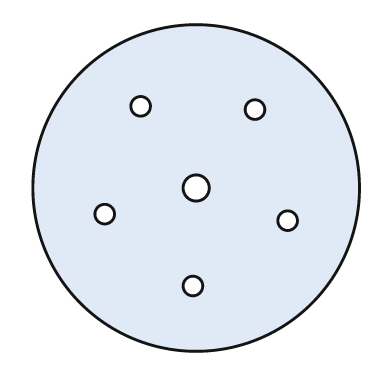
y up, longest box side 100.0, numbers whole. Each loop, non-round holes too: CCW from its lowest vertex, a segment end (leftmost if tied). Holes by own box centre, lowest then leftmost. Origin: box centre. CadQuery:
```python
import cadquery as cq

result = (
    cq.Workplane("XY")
    .moveTo(0.0, 0.0)
    .circle(50.0)
    .moveTo(-1.0, -30.0)
    .circle(3.0)
    .moveTo(28.0, -10.0)
    .circle(3.0)
    .moveTo(-28.0, -8.0)
    .circle(3.0)
    .moveTo(0.0, 0.0)
    .circle(4.0)
    .moveTo(18.0, 24.0)
    .circle(3.0)
    .moveTo(-17.0, 25.0)
    .circle(3.0)
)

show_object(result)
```